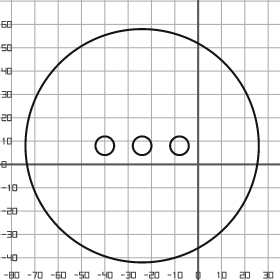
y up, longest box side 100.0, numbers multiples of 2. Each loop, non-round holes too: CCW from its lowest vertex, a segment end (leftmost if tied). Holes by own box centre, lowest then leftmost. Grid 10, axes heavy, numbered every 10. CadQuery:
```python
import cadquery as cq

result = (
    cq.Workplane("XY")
    .moveTo(-24.0, 8.0)
    .circle(50.0)
    .moveTo(-40.0, 8.0)
    .circle(4.0)
    .moveTo(-24.0, 8.0)
    .circle(4.0)
    .moveTo(-8.0, 8.0)
    .circle(4.0)
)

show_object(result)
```